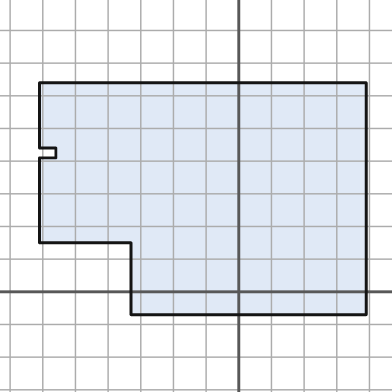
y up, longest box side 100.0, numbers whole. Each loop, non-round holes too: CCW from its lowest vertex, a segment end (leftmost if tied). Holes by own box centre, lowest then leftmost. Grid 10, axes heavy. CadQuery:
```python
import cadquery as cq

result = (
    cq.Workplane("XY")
    .moveTo(-33.0, -7.0)
    .lineTo(39.0, -7.0)
    .lineTo(39.0, 64.0)
    .lineTo(-61.0, 64.0)
    .lineTo(-61.0, 44.0)
    .lineTo(-56.0, 44.0)
    .lineTo(-56.0, 41.0)
    .lineTo(-61.0, 41.0)
    .lineTo(-61.0, 15.0)
    .lineTo(-33.0, 15.0)
    .close()
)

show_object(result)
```